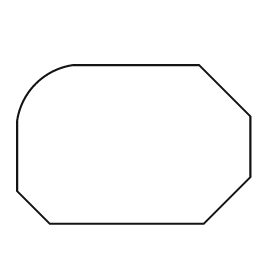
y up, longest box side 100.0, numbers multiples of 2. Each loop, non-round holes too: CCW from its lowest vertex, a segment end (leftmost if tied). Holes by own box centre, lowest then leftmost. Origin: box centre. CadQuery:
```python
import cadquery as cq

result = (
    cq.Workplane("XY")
    .moveTo(-36.0, -34.0)
    .lineTo(30.0, -34.0)
    .lineTo(50.0, -14.0)
    .lineTo(50.0, 12.0)
    .lineTo(28.0, 34.0)
    .lineTo(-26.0, 34.0)
    .threePointArc((-42.0, 26.0), (-50.0, 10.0))
    .lineTo(-50.0, -20.0)
    .close()
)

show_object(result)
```